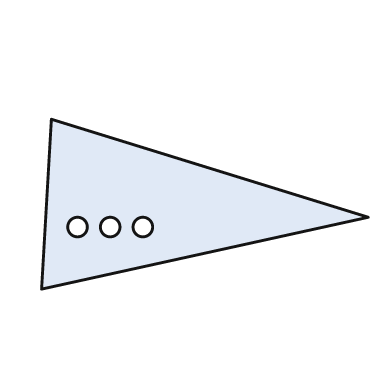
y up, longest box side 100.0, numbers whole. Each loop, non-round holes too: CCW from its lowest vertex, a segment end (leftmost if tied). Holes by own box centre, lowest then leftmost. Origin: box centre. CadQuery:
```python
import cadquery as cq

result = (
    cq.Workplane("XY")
    .moveTo(-50.0, -26.0)
    .lineTo(50.0, -4.0)
    .lineTo(-47.0, 26.0)
    .close()
    .moveTo(-39.0, -7.0)
    .circle(3.0)
    .moveTo(-29.0, -7.0)
    .circle(3.0)
    .moveTo(-19.0, -7.0)
    .circle(3.0)
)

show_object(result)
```